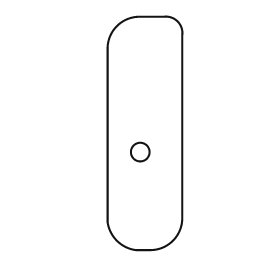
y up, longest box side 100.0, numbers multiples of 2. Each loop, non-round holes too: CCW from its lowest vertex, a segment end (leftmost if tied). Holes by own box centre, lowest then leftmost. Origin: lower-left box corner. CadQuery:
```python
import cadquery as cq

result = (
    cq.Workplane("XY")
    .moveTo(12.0, 0.0)
    .lineTo(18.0, 0.0)
    .threePointArc((28.0, 4.0), (32.0, 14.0))
    .lineTo(32.0, 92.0)
    .threePointArc((30.0, 98.0), (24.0, 100.0))
    .lineTo(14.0, 100.0)
    .threePointArc((4.0, 96.0), (0.0, 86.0))
    .lineTo(0.0, 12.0)
    .threePointArc((4.0, 4.0), (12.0, 0.0))
    .close()
    .moveTo(14.0, 42.0)
    .circle(4.0)
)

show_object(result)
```